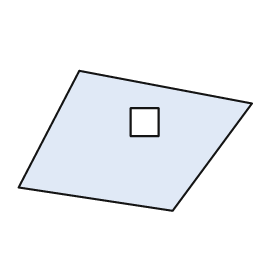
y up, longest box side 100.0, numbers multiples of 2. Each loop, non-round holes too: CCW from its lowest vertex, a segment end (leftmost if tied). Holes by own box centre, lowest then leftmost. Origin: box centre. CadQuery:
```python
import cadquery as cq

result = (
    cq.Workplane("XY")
    .moveTo(16.0, -30.0)
    .lineTo(50.0, 16.0)
    .lineTo(-24.0, 30.0)
    .lineTo(-50.0, -20.0)
    .close()
    .moveTo(-2.0, 2.0)
    .lineTo(10.0, 2.0)
    .lineTo(10.0, 14.0)
    .lineTo(-2.0, 14.0)
    .close()
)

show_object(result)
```